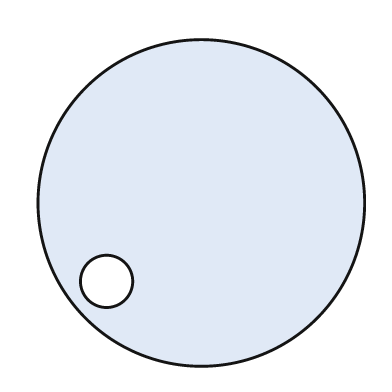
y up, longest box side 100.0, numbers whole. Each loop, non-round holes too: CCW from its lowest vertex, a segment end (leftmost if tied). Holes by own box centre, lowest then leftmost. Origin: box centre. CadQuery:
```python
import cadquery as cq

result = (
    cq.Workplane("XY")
    .moveTo(0.0, 0.0)
    .circle(50.0)
    .moveTo(-29.0, -24.0)
    .circle(8.0)
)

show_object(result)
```